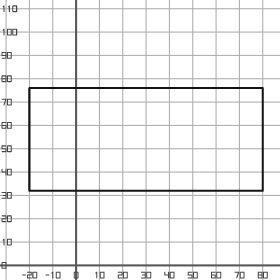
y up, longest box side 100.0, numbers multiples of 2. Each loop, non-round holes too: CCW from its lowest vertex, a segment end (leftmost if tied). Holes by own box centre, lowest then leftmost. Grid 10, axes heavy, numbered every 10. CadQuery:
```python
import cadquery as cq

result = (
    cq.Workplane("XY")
    .moveTo(-20.0, 32.0)
    .lineTo(80.0, 32.0)
    .lineTo(80.0, 76.0)
    .lineTo(-20.0, 76.0)
    .close()
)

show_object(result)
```